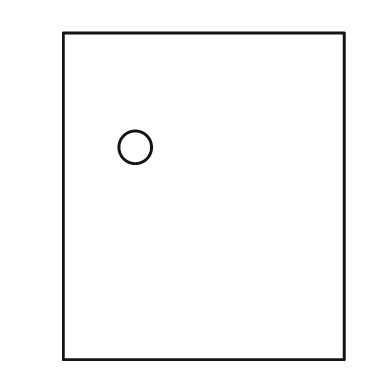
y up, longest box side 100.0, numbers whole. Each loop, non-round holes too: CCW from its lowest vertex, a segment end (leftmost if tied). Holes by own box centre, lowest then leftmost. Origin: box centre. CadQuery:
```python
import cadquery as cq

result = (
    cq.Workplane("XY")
    .moveTo(-43.0, -50.0)
    .lineTo(43.0, -50.0)
    .lineTo(43.0, 50.0)
    .lineTo(-43.0, 50.0)
    .close()
    .moveTo(-21.0, 15.0)
    .circle(5.0)
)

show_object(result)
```